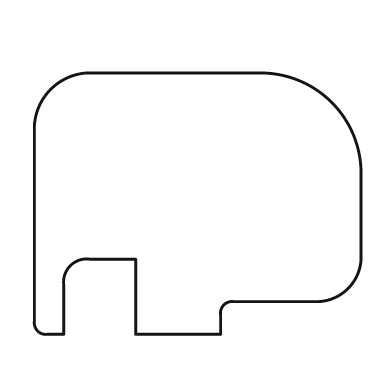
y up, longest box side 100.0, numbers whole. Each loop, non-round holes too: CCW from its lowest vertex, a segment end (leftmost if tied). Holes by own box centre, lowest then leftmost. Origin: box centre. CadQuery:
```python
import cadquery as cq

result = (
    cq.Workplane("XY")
    .moveTo(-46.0, -40.0)
    .lineTo(-41.0, -40.0)
    .lineTo(-41.0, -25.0)
    .threePointArc((-39.0, -19.0), (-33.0, -17.0))
    .lineTo(-19.0, -17.0)
    .lineTo(-19.0, -40.0)
    .lineTo(7.0, -40.0)
    .lineTo(7.0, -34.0)
    .threePointArc((8.0, -31.0), (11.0, -30.0))
    .lineTo(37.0, -30.0)
    .threePointArc((46.0, -26.0), (50.0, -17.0))
    .lineTo(50.0, 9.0)
    .threePointArc((41.0, 31.0), (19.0, 40.0))
    .lineTo(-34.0, 40.0)
    .threePointArc((-45.0, 35.0), (-50.0, 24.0))
    .lineTo(-50.0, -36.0)
    .threePointArc((-49.0, -39.0), (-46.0, -40.0))
    .close()
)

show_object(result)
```